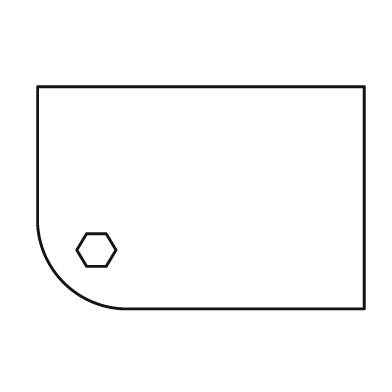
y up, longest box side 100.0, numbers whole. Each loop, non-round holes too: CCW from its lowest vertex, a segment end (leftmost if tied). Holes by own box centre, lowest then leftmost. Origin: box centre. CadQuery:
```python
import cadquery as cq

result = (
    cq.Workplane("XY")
    .moveTo(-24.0, -34.0)
    .lineTo(50.0, -34.0)
    .lineTo(50.0, 34.0)
    .lineTo(-50.0, 34.0)
    .lineTo(-50.0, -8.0)
    .threePointArc((-42.0, -26.0), (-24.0, -34.0))
    .close()
    .moveTo(-35.0, -21.0)
    .lineTo(-29.0, -21.0)
    .lineTo(-26.0, -16.0)
    .lineTo(-29.0, -11.0)
    .lineTo(-35.0, -11.0)
    .lineTo(-38.0, -16.0)
    .close()
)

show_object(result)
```